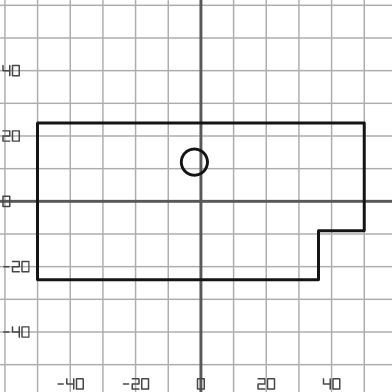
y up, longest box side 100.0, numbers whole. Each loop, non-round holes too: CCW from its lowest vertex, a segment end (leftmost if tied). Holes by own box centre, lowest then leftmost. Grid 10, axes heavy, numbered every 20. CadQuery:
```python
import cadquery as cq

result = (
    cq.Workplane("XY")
    .moveTo(-50.0, -24.0)
    .lineTo(36.0, -24.0)
    .lineTo(36.0, -9.0)
    .lineTo(50.0, -9.0)
    .lineTo(50.0, 24.0)
    .lineTo(-50.0, 24.0)
    .close()
    .moveTo(-2.0, 12.0)
    .circle(4.0)
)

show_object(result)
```